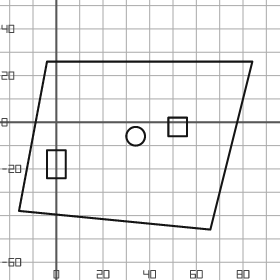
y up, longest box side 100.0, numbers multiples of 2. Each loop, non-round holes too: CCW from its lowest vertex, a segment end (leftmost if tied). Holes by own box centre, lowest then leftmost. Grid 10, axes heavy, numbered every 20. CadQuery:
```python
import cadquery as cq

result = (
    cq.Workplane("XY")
    .moveTo(66.0, -46.0)
    .lineTo(84.0, 26.0)
    .lineTo(-4.0, 26.0)
    .lineTo(-16.0, -38.0)
    .close()
    .moveTo(-4.0, -24.0)
    .lineTo(4.0, -24.0)
    .lineTo(4.0, -12.0)
    .lineTo(-4.0, -12.0)
    .close()
    .moveTo(34.0, -6.0)
    .circle(4.0)
    .moveTo(48.0, -6.0)
    .lineTo(56.0, -6.0)
    .lineTo(56.0, 2.0)
    .lineTo(48.0, 2.0)
    .close()
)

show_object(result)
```